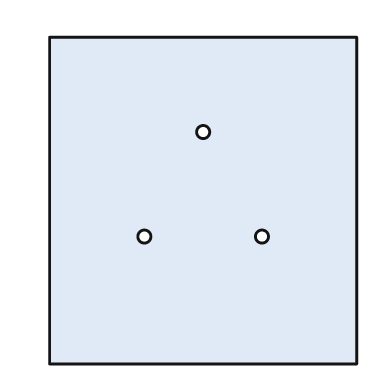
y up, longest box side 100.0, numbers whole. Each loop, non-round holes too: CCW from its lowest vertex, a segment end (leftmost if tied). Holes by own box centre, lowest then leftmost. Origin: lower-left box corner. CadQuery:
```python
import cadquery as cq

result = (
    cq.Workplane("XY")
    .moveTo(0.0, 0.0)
    .lineTo(94.0, 0.0)
    .lineTo(94.0, 100.0)
    .lineTo(0.0, 100.0)
    .close()
    .moveTo(29.0, 39.0)
    .circle(2.0)
    .moveTo(65.0, 39.0)
    .circle(2.0)
    .moveTo(47.0, 71.0)
    .circle(2.0)
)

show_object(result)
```